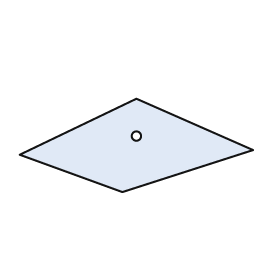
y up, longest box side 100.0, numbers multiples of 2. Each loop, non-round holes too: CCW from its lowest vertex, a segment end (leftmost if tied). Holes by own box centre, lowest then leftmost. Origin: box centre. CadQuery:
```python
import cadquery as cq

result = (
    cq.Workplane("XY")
    .moveTo(-6.0, -20.0)
    .lineTo(50.0, -2.0)
    .lineTo(0.0, 20.0)
    .lineTo(-50.0, -4.0)
    .close()
    .moveTo(0.0, 4.0)
    .circle(2.0)
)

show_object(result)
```